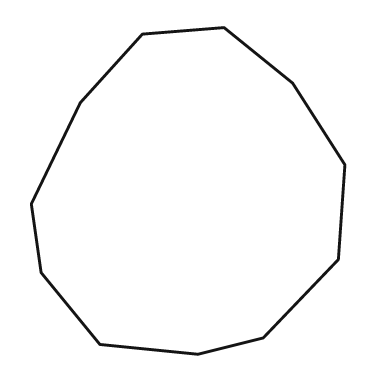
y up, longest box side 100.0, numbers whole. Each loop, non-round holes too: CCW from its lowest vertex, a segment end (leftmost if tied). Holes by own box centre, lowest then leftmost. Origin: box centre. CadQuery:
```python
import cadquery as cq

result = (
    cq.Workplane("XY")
    .moveTo(3.0, -50.0)
    .lineTo(23.0, -45.0)
    .lineTo(46.0, -21.0)
    .lineTo(48.0, 8.0)
    .lineTo(32.0, 33.0)
    .lineTo(11.0, 50.0)
    .lineTo(-14.0, 48.0)
    .lineTo(-33.0, 27.0)
    .lineTo(-48.0, -4.0)
    .lineTo(-45.0, -25.0)
    .lineTo(-27.0, -47.0)
    .close()
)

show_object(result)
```